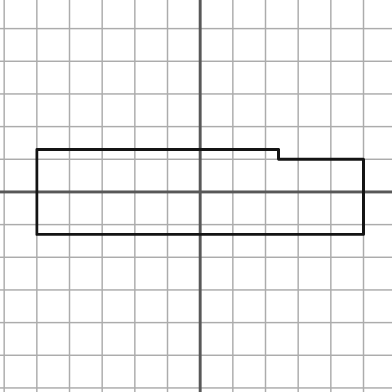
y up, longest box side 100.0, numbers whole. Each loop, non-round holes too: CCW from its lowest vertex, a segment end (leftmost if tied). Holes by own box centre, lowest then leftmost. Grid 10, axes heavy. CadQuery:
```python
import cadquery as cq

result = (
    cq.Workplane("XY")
    .moveTo(-50.0, -13.0)
    .lineTo(50.0, -13.0)
    .lineTo(50.0, 10.0)
    .lineTo(24.0, 10.0)
    .lineTo(24.0, 13.0)
    .lineTo(-50.0, 13.0)
    .close()
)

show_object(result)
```